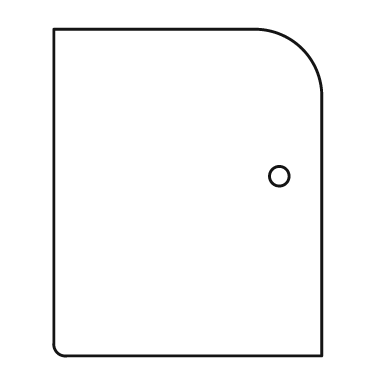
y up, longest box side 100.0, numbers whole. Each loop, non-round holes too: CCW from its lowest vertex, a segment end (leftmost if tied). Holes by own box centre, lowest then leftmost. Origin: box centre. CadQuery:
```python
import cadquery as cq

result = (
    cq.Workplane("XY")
    .moveTo(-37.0, -50.0)
    .lineTo(41.0, -50.0)
    .lineTo(41.0, 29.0)
    .threePointArc((35.0, 44.0), (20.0, 50.0))
    .lineTo(-41.0, 50.0)
    .lineTo(-41.0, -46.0)
    .threePointArc((-40.0, -49.0), (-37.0, -50.0))
    .close()
    .moveTo(28.0, 5.0)
    .circle(3.0)
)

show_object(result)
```